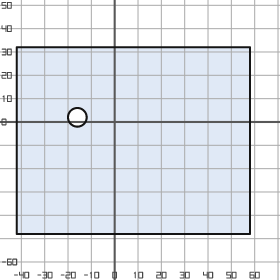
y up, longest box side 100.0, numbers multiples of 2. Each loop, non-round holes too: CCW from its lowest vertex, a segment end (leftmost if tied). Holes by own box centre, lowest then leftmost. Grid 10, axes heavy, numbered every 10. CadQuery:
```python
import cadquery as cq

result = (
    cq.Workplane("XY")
    .moveTo(-42.0, -48.0)
    .lineTo(58.0, -48.0)
    .lineTo(58.0, 32.0)
    .lineTo(-42.0, 32.0)
    .close()
    .moveTo(-16.0, 2.0)
    .circle(4.0)
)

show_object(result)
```